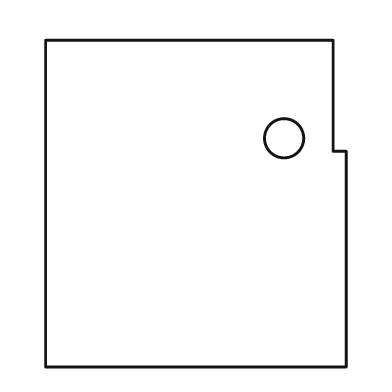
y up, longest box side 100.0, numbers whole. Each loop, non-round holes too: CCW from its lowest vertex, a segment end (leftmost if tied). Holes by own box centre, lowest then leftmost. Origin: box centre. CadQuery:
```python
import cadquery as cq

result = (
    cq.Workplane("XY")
    .moveTo(-46.0, -50.0)
    .lineTo(46.0, -50.0)
    .lineTo(46.0, 16.0)
    .lineTo(42.0, 16.0)
    .lineTo(42.0, 50.0)
    .lineTo(-46.0, 50.0)
    .close()
    .moveTo(27.0, 20.0)
    .circle(6.0)
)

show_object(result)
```